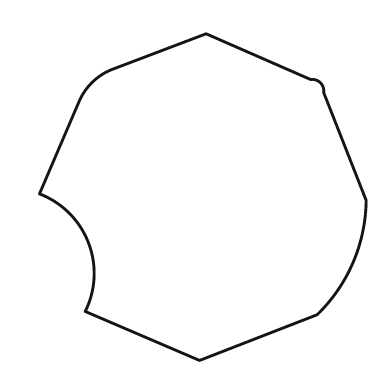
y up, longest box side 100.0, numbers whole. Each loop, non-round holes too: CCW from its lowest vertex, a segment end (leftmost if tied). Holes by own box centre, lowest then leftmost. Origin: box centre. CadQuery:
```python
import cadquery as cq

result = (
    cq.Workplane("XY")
    .moveTo(-1.0, -50.0)
    .lineTo(35.0, -36.0)
    .threePointArc((46.0, -20.0), (50.0, -1.0))
    .lineTo(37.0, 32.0)
    .threePointArc((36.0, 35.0), (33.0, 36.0))
    .lineTo(1.0, 50.0)
    .lineTo(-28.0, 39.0)
    .threePointArc((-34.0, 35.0), (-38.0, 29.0))
    .lineTo(-50.0, 1.0)
    .threePointArc((-35.0, -14.0), (-36.0, -35.0))
    .close()
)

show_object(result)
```